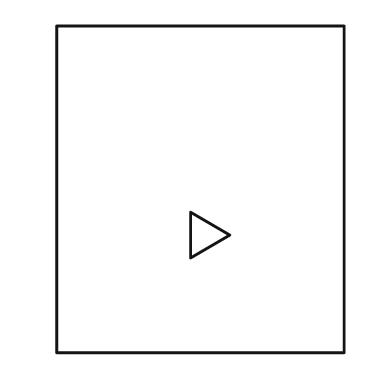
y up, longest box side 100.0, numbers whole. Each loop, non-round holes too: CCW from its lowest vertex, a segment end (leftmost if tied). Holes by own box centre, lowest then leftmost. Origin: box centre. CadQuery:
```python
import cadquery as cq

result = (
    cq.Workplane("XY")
    .moveTo(-44.0, -50.0)
    .lineTo(44.0, -50.0)
    .lineTo(44.0, 50.0)
    .lineTo(-44.0, 50.0)
    .close()
    .moveTo(-3.0, -21.0)
    .lineTo(9.0, -14.0)
    .lineTo(-3.0, -7.0)
    .close()
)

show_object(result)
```